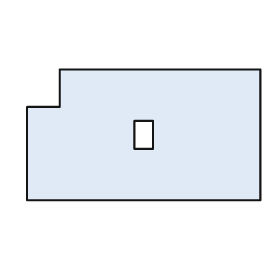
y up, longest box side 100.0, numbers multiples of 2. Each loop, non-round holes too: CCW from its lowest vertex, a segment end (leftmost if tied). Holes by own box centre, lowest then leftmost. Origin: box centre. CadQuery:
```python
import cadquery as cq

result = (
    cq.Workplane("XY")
    .moveTo(-50.0, -28.0)
    .lineTo(50.0, -28.0)
    .lineTo(50.0, 28.0)
    .lineTo(-36.0, 28.0)
    .lineTo(-36.0, 12.0)
    .lineTo(-50.0, 12.0)
    .close()
    .moveTo(-4.0, -6.0)
    .lineTo(4.0, -6.0)
    .lineTo(4.0, 6.0)
    .lineTo(-4.0, 6.0)
    .close()
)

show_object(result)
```